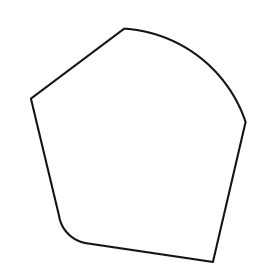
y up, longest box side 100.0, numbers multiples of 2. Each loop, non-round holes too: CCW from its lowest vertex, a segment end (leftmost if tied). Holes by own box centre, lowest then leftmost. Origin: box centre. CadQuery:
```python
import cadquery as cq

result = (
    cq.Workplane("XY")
    .moveTo(32.0, -50.0)
    .lineTo(46.0, 10.0)
    .threePointArc((26.0, 38.0), (-6.0, 50.0))
    .lineTo(-46.0, 20.0)
    .lineTo(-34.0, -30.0)
    .threePointArc((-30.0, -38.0), (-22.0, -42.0))
    .close()
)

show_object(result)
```